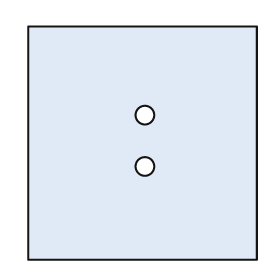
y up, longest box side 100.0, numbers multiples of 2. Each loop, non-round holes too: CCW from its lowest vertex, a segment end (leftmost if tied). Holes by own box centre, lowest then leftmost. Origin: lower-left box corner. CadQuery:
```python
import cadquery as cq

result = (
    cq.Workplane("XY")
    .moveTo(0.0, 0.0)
    .lineTo(98.0, 0.0)
    .lineTo(98.0, 100.0)
    .lineTo(0.0, 100.0)
    .close()
    .moveTo(50.0, 40.0)
    .circle(4.0)
    .moveTo(50.0, 62.0)
    .circle(4.0)
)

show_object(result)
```